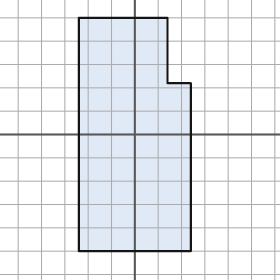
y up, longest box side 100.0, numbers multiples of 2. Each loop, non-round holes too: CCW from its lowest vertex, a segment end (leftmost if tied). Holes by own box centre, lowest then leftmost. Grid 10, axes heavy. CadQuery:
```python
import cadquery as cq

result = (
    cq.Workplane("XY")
    .moveTo(-24.0, -50.0)
    .lineTo(24.0, -50.0)
    .lineTo(24.0, 22.0)
    .lineTo(14.0, 22.0)
    .lineTo(14.0, 50.0)
    .lineTo(-24.0, 50.0)
    .close()
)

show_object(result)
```